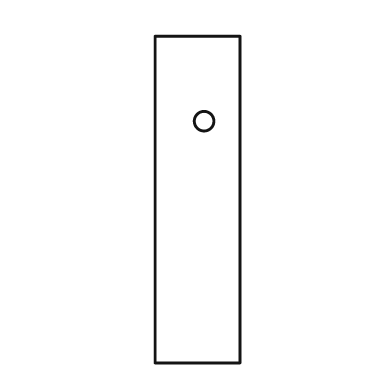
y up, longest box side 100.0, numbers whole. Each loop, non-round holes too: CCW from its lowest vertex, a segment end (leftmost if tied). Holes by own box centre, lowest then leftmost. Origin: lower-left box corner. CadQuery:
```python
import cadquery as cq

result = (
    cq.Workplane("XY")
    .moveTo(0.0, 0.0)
    .lineTo(26.0, 0.0)
    .lineTo(26.0, 100.0)
    .lineTo(0.0, 100.0)
    .close()
    .moveTo(15.0, 74.0)
    .circle(3.0)
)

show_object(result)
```